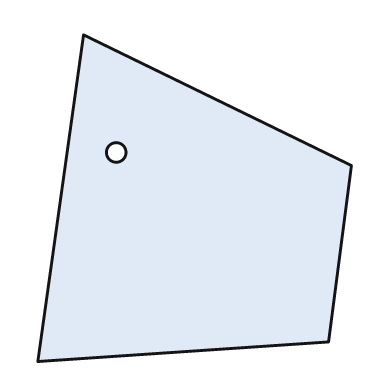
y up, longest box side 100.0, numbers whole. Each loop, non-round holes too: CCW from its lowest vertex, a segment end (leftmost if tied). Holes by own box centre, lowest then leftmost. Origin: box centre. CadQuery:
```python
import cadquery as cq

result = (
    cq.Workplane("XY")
    .moveTo(-48.0, -50.0)
    .lineTo(41.0, -44.0)
    .lineTo(48.0, 10.0)
    .lineTo(-34.0, 50.0)
    .close()
    .moveTo(-24.0, 14.0)
    .circle(3.0)
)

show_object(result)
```